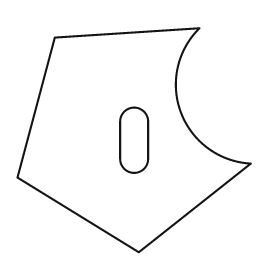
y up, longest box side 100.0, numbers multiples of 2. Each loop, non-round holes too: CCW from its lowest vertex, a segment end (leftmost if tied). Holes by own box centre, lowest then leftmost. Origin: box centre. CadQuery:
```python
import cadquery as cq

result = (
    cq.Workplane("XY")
    .moveTo(2.0, -48.0)
    .lineTo(50.0, -10.0)
    .threePointArc((20.0, 12.0), (28.0, 48.0))
    .lineTo(-34.0, 44.0)
    .lineTo(-50.0, -16.0)
    .close()
    .moveTo(-6.0, -8.0)
    .threePointArc((0.0, -14.0), (6.0, -8.0))
    .lineTo(6.0, 8.0)
    .threePointArc((0.0, 14.0), (-6.0, 8.0))
    .close()
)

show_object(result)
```